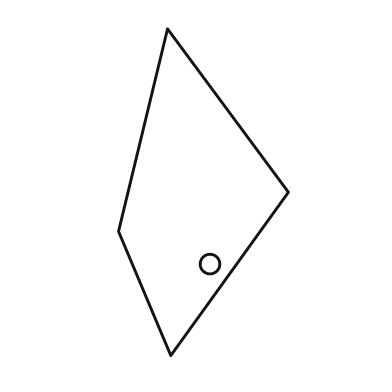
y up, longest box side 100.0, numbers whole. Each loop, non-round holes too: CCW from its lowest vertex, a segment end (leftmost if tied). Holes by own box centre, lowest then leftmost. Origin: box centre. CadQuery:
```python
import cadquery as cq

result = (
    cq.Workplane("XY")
    .moveTo(-10.0, -50.0)
    .lineTo(26.0, 0.0)
    .lineTo(-11.0, 50.0)
    .lineTo(-26.0, -12.0)
    .close()
    .moveTo(2.0, -22.0)
    .circle(3.0)
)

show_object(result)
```